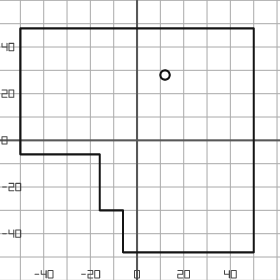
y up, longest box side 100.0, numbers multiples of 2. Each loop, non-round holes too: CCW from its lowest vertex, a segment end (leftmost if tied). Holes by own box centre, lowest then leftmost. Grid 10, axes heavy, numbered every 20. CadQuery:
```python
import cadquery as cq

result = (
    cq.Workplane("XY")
    .moveTo(-6.0, -48.0)
    .lineTo(50.0, -48.0)
    .lineTo(50.0, 48.0)
    .lineTo(-50.0, 48.0)
    .lineTo(-50.0, -6.0)
    .lineTo(-16.0, -6.0)
    .lineTo(-16.0, -30.0)
    .lineTo(-6.0, -30.0)
    .close()
    .moveTo(12.0, 28.0)
    .circle(2.0)
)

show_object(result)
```